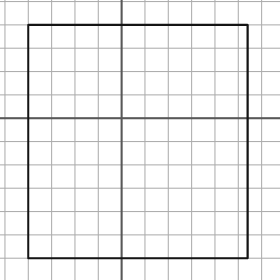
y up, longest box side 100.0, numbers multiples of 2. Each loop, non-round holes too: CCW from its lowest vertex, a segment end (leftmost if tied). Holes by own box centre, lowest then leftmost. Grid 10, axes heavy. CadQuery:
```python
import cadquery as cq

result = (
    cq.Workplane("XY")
    .moveTo(-40.0, -60.0)
    .lineTo(54.0, -60.0)
    .lineTo(54.0, 40.0)
    .lineTo(-40.0, 40.0)
    .close()
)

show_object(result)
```